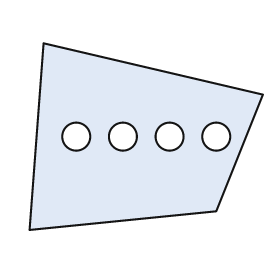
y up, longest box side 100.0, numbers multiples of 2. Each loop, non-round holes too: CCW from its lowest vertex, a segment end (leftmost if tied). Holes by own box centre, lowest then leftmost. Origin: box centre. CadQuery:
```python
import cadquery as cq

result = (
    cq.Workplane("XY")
    .moveTo(-50.0, -40.0)
    .lineTo(30.0, -32.0)
    .lineTo(50.0, 18.0)
    .lineTo(-44.0, 40.0)
    .close()
    .moveTo(-30.0, 0.0)
    .circle(6.0)
    .moveTo(-10.0, 0.0)
    .circle(6.0)
    .moveTo(10.0, 0.0)
    .circle(6.0)
    .moveTo(30.0, 0.0)
    .circle(6.0)
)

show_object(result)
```